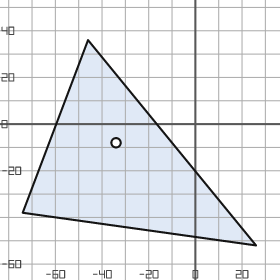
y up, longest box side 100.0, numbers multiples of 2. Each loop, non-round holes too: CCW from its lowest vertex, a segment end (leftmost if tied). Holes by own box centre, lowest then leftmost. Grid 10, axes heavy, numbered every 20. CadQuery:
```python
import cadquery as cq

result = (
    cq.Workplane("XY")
    .moveTo(26.0, -52.0)
    .lineTo(-46.0, 36.0)
    .lineTo(-74.0, -38.0)
    .close()
    .moveTo(-34.0, -8.0)
    .circle(2.0)
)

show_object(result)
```